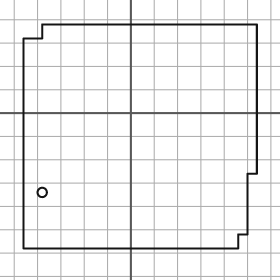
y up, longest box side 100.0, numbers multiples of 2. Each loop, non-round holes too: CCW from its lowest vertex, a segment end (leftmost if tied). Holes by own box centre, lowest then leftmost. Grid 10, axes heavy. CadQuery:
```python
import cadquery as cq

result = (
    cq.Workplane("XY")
    .moveTo(-46.0, -58.0)
    .lineTo(46.0, -58.0)
    .lineTo(46.0, -52.0)
    .lineTo(50.0, -52.0)
    .lineTo(50.0, -26.0)
    .lineTo(54.0, -26.0)
    .lineTo(54.0, 38.0)
    .lineTo(-38.0, 38.0)
    .lineTo(-38.0, 32.0)
    .lineTo(-46.0, 32.0)
    .close()
    .moveTo(-38.0, -34.0)
    .circle(2.0)
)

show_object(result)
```